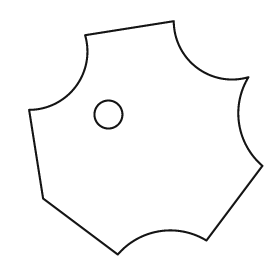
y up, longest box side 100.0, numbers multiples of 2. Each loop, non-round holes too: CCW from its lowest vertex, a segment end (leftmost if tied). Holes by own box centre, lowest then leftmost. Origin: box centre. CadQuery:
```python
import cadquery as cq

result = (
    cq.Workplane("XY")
    .moveTo(-12.0, -50.0)
    .threePointArc((6.0, -40.0), (26.0, -44.0))
    .lineTo(50.0, -12.0)
    .threePointArc((40.0, 6.0), (44.0, 26.0))
    .threePointArc((22.0, 30.0), (12.0, 50.0))
    .lineTo(-26.0, 44.0)
    .threePointArc((-30.0, 22.0), (-50.0, 12.0))
    .lineTo(-44.0, -26.0)
    .close()
    .moveTo(-16.0, 10.0)
    .circle(6.0)
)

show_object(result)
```